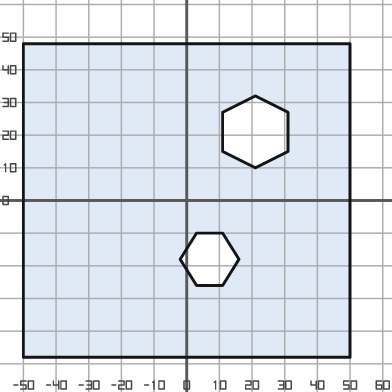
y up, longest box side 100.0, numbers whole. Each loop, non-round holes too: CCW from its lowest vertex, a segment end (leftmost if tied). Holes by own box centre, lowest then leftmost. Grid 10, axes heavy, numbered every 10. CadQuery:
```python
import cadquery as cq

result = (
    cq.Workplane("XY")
    .moveTo(-50.0, -48.0)
    .lineTo(50.0, -48.0)
    .lineTo(50.0, 48.0)
    .lineTo(-50.0, 48.0)
    .close()
    .moveTo(3.0, -26.0)
    .lineTo(11.0, -26.0)
    .lineTo(16.0, -18.0)
    .lineTo(11.0, -10.0)
    .lineTo(3.0, -10.0)
    .lineTo(-2.0, -18.0)
    .close()
    .moveTo(21.0, 10.0)
    .lineTo(31.0, 15.0)
    .lineTo(31.0, 27.0)
    .lineTo(21.0, 32.0)
    .lineTo(11.0, 27.0)
    .lineTo(11.0, 15.0)
    .close()
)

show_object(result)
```